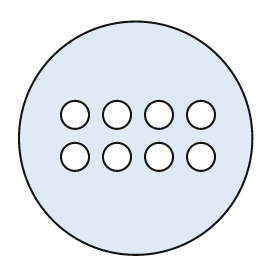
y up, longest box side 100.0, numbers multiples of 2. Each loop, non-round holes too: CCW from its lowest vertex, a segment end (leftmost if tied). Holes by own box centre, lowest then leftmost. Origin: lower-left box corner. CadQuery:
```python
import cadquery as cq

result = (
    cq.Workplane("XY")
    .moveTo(50.0, 50.0)
    .circle(50.0)
    .moveTo(24.0, 42.0)
    .circle(6.0)
    .moveTo(42.0, 42.0)
    .circle(6.0)
    .moveTo(60.0, 42.0)
    .circle(6.0)
    .moveTo(78.0, 42.0)
    .circle(6.0)
    .moveTo(24.0, 60.0)
    .circle(6.0)
    .moveTo(42.0, 60.0)
    .circle(6.0)
    .moveTo(60.0, 60.0)
    .circle(6.0)
    .moveTo(78.0, 60.0)
    .circle(6.0)
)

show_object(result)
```